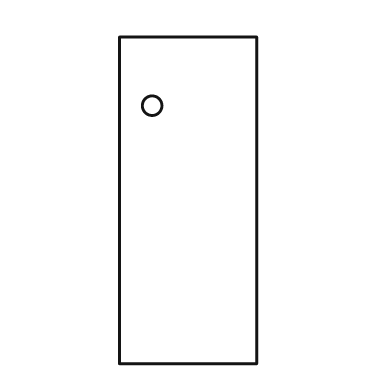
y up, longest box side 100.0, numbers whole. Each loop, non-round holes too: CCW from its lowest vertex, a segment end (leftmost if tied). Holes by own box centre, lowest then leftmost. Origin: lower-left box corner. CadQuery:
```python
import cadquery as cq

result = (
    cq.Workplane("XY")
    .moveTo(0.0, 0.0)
    .lineTo(42.0, 0.0)
    .lineTo(42.0, 100.0)
    .lineTo(0.0, 100.0)
    .close()
    .moveTo(10.0, 79.0)
    .circle(3.0)
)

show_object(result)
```